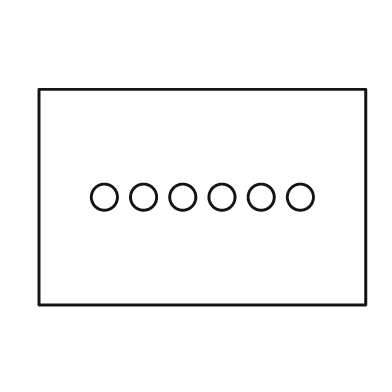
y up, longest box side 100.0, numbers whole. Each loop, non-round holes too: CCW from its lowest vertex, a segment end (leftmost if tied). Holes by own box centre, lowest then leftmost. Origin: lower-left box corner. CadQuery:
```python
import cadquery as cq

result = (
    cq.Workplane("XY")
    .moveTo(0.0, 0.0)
    .lineTo(100.0, 0.0)
    .lineTo(100.0, 66.0)
    .lineTo(0.0, 66.0)
    .close()
    .moveTo(20.0, 33.0)
    .circle(4.0)
    .moveTo(32.0, 33.0)
    .circle(4.0)
    .moveTo(44.0, 33.0)
    .circle(4.0)
    .moveTo(56.0, 33.0)
    .circle(4.0)
    .moveTo(68.0, 33.0)
    .circle(4.0)
    .moveTo(80.0, 33.0)
    .circle(4.0)
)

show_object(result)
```